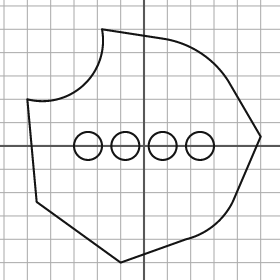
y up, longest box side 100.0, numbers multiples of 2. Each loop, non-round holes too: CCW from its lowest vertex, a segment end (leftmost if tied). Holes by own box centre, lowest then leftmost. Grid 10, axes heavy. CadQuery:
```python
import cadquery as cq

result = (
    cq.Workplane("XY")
    .moveTo(-10.0, -50.0)
    .lineTo(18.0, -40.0)
    .threePointArc((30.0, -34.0), (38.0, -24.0))
    .lineTo(50.0, 4.0)
    .lineTo(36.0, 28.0)
    .threePointArc((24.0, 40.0), (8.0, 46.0))
    .lineTo(-18.0, 50.0)
    .threePointArc((-26.0, 26.0), (-50.0, 20.0))
    .lineTo(-46.0, -24.0)
    .close()
    .moveTo(-24.0, 0.0)
    .circle(6.0)
    .moveTo(-8.0, 0.0)
    .circle(6.0)
    .moveTo(8.0, 0.0)
    .circle(6.0)
    .moveTo(24.0, 0.0)
    .circle(6.0)
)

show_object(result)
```